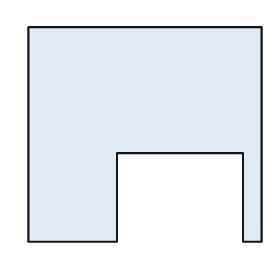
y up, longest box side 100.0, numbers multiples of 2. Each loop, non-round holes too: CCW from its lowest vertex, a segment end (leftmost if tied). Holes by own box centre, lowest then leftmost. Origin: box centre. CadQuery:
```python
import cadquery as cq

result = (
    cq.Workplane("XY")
    .moveTo(-50.0, -46.0)
    .lineTo(-12.0, -46.0)
    .lineTo(-12.0, -8.0)
    .lineTo(42.0, -8.0)
    .lineTo(42.0, -46.0)
    .lineTo(50.0, -46.0)
    .lineTo(50.0, 46.0)
    .lineTo(-50.0, 46.0)
    .close()
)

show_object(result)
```